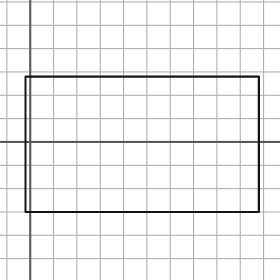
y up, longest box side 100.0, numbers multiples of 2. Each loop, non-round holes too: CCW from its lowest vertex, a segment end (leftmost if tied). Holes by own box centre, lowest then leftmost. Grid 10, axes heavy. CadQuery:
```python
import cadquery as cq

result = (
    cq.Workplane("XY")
    .moveTo(-2.0, -30.0)
    .lineTo(98.0, -30.0)
    .lineTo(98.0, 28.0)
    .lineTo(-2.0, 28.0)
    .close()
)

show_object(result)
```